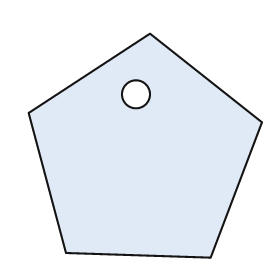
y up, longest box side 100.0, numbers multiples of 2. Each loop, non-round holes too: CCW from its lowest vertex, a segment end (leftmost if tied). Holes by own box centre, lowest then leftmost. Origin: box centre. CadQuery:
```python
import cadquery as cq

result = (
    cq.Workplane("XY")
    .moveTo(28.0, -48.0)
    .lineTo(50.0, 10.0)
    .lineTo(2.0, 48.0)
    .lineTo(-50.0, 14.0)
    .lineTo(-34.0, -46.0)
    .close()
    .moveTo(-4.0, 22.0)
    .circle(6.0)
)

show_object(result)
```